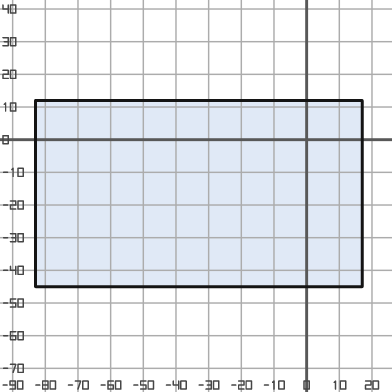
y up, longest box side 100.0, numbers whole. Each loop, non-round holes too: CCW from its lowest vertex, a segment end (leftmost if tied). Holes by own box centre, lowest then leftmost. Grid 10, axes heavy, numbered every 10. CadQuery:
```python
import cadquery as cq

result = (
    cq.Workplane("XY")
    .moveTo(-83.0, -45.0)
    .lineTo(17.0, -45.0)
    .lineTo(17.0, 12.0)
    .lineTo(-83.0, 12.0)
    .close()
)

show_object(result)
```